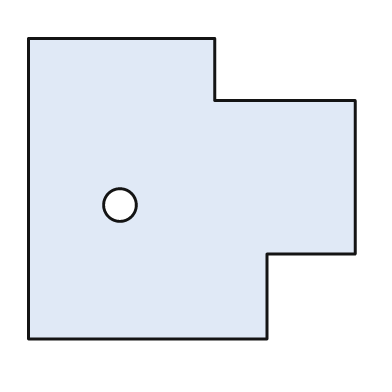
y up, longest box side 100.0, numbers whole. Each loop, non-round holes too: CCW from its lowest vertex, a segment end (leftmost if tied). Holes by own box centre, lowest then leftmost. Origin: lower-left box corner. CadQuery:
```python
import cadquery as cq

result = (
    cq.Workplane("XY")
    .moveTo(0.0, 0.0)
    .lineTo(73.0, 0.0)
    .lineTo(73.0, 26.0)
    .lineTo(100.0, 26.0)
    .lineTo(100.0, 73.0)
    .lineTo(57.0, 73.0)
    .lineTo(57.0, 92.0)
    .lineTo(0.0, 92.0)
    .close()
    .moveTo(28.0, 41.0)
    .circle(5.0)
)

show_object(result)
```